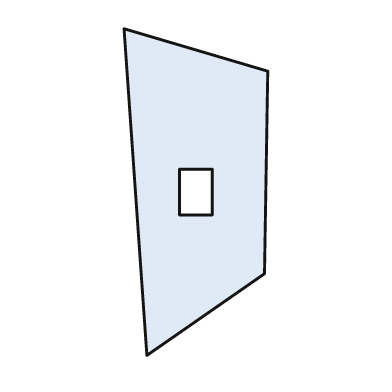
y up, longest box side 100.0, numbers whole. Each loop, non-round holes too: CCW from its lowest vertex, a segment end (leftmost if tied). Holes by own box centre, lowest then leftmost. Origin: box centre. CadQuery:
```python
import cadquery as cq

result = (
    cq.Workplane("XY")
    .moveTo(-15.0, -50.0)
    .lineTo(21.0, -25.0)
    .lineTo(22.0, 37.0)
    .lineTo(-22.0, 50.0)
    .close()
    .moveTo(-5.0, -7.0)
    .lineTo(5.0, -7.0)
    .lineTo(5.0, 7.0)
    .lineTo(-5.0, 7.0)
    .close()
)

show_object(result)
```